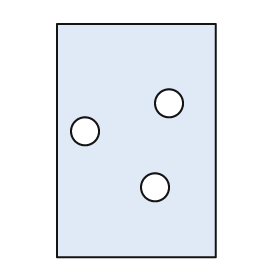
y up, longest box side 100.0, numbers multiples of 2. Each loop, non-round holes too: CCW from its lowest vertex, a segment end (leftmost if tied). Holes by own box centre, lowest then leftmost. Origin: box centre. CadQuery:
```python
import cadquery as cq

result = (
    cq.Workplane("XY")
    .moveTo(-34.0, -50.0)
    .lineTo(34.0, -50.0)
    .lineTo(34.0, 50.0)
    .lineTo(-34.0, 50.0)
    .close()
    .moveTo(8.0, -20.0)
    .circle(6.0)
    .moveTo(-22.0, 4.0)
    .circle(6.0)
    .moveTo(14.0, 16.0)
    .circle(6.0)
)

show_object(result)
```